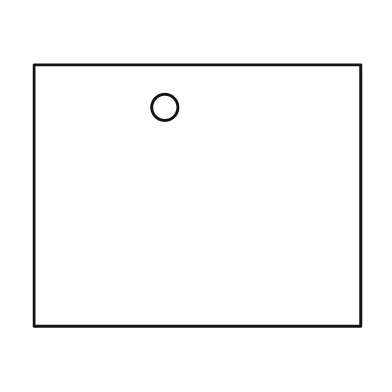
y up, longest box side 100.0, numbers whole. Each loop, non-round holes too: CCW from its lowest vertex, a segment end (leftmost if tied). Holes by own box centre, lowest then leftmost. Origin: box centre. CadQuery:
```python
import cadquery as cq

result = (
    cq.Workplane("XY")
    .moveTo(-50.0, -40.0)
    .lineTo(50.0, -40.0)
    .lineTo(50.0, 40.0)
    .lineTo(-50.0, 40.0)
    .close()
    .moveTo(-10.0, 27.0)
    .circle(4.0)
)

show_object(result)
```